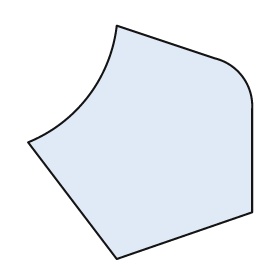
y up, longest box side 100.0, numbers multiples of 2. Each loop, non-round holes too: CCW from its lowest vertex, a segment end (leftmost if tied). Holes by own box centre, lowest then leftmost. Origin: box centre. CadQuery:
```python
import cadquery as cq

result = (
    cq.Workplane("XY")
    .moveTo(-10.0, -50.0)
    .lineTo(48.0, -30.0)
    .lineTo(48.0, 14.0)
    .threePointArc((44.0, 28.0), (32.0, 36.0))
    .lineTo(-10.0, 50.0)
    .threePointArc((-22.0, 20.0), (-48.0, 0.0))
    .close()
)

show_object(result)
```